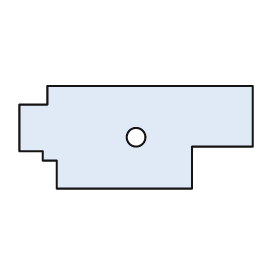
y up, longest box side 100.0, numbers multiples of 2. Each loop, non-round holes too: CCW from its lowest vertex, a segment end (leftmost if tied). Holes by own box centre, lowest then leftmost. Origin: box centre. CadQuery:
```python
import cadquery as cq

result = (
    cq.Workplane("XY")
    .moveTo(-34.0, -22.0)
    .lineTo(24.0, -22.0)
    .lineTo(24.0, -4.0)
    .lineTo(50.0, -4.0)
    .lineTo(50.0, 22.0)
    .lineTo(-38.0, 22.0)
    .lineTo(-38.0, 14.0)
    .lineTo(-50.0, 14.0)
    .lineTo(-50.0, -6.0)
    .lineTo(-40.0, -6.0)
    .lineTo(-40.0, -10.0)
    .lineTo(-34.0, -10.0)
    .close()
    .moveTo(0.0, 0.0)
    .circle(4.0)
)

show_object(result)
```